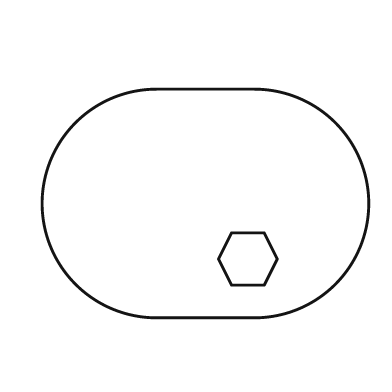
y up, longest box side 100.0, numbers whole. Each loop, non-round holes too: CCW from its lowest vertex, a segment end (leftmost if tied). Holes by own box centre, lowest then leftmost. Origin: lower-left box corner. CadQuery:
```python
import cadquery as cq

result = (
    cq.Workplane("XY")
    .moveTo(35.0, 0.0)
    .lineTo(65.0, 0.0)
    .threePointArc((100.0, 35.0), (65.0, 70.0))
    .lineTo(35.0, 70.0)
    .threePointArc((0.0, 35.0), (35.0, 0.0))
    .close()
    .moveTo(58.0, 10.0)
    .lineTo(68.0, 10.0)
    .lineTo(72.0, 18.0)
    .lineTo(68.0, 26.0)
    .lineTo(58.0, 26.0)
    .lineTo(54.0, 18.0)
    .close()
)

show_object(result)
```